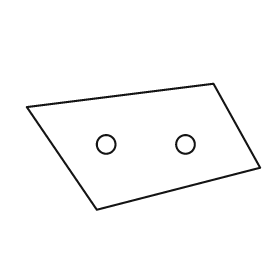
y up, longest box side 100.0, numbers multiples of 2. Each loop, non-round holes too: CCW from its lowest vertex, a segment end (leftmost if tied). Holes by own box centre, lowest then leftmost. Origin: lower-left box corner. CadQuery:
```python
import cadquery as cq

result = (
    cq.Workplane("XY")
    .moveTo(30.0, 0.0)
    .lineTo(100.0, 18.0)
    .lineTo(80.0, 54.0)
    .lineTo(0.0, 44.0)
    .close()
    .moveTo(34.0, 28.0)
    .circle(4.0)
    .moveTo(68.0, 28.0)
    .circle(4.0)
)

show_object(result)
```